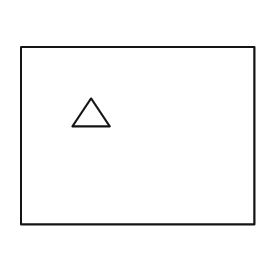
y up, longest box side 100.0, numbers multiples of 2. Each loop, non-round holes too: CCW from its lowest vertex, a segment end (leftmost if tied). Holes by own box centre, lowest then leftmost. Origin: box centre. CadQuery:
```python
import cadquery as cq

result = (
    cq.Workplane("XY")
    .moveTo(-50.0, -38.0)
    .lineTo(50.0, -38.0)
    .lineTo(50.0, 38.0)
    .lineTo(-50.0, 38.0)
    .close()
    .moveTo(-28.0, 4.0)
    .lineTo(-12.0, 4.0)
    .lineTo(-20.0, 16.0)
    .close()
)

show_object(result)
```